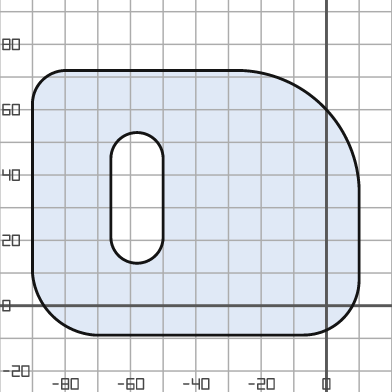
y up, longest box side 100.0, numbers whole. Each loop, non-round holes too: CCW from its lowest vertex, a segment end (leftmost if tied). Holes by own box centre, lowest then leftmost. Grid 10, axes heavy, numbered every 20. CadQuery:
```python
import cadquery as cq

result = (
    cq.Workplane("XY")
    .moveTo(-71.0, -9.0)
    .lineTo(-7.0, -9.0)
    .threePointArc((5.0, -4.0), (10.0, 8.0))
    .lineTo(10.0, 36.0)
    .threePointArc((-1.0, 61.0), (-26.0, 72.0))
    .lineTo(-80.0, 72.0)
    .threePointArc((-87.0, 69.0), (-90.0, 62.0))
    .lineTo(-90.0, 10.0)
    .threePointArc((-84.0, -3.0), (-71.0, -9.0))
    .close()
    .moveTo(-66.0, 21.0)
    .threePointArc((-58.0, 13.0), (-50.0, 21.0))
    .lineTo(-50.0, 45.0)
    .threePointArc((-58.0, 53.0), (-66.0, 45.0))
    .close()
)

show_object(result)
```